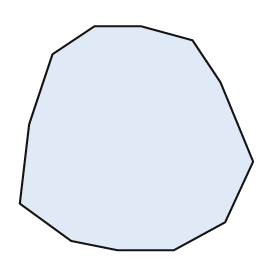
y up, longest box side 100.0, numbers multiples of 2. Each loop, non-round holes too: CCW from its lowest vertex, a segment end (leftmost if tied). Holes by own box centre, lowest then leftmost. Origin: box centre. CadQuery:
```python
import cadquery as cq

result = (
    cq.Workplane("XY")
    .moveTo(-8.0, -48.0)
    .lineTo(16.0, -48.0)
    .lineTo(38.0, -36.0)
    .lineTo(50.0, -10.0)
    .lineTo(36.0, 24.0)
    .lineTo(24.0, 42.0)
    .lineTo(2.0, 48.0)
    .lineTo(-18.0, 48.0)
    .lineTo(-36.0, 36.0)
    .lineTo(-46.0, 6.0)
    .lineTo(-50.0, -28.0)
    .lineTo(-28.0, -44.0)
    .close()
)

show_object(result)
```